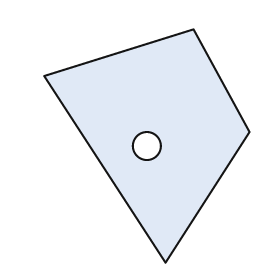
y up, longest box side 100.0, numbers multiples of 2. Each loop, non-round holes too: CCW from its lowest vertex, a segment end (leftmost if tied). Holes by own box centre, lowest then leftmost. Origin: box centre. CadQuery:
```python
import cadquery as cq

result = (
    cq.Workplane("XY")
    .moveTo(8.0, -50.0)
    .lineTo(44.0, 6.0)
    .lineTo(20.0, 50.0)
    .lineTo(-44.0, 30.0)
    .close()
    .moveTo(0.0, 0.0)
    .circle(6.0)
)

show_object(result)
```